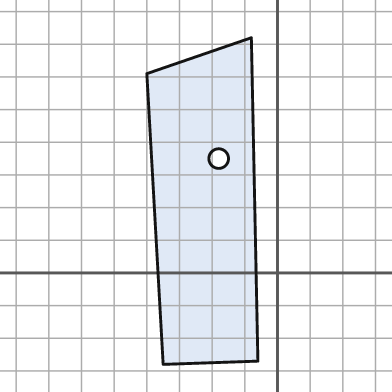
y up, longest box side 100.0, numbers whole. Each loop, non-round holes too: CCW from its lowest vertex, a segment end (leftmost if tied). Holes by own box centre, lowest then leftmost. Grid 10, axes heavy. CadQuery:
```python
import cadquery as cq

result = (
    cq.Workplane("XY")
    .moveTo(-35.0, -28.0)
    .lineTo(-6.0, -27.0)
    .lineTo(-8.0, 72.0)
    .lineTo(-40.0, 61.0)
    .close()
    .moveTo(-18.0, 35.0)
    .circle(3.0)
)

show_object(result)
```